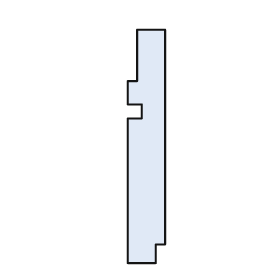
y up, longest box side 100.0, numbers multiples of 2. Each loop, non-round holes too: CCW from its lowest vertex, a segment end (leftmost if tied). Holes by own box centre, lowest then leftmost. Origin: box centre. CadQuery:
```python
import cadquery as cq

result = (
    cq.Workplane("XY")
    .moveTo(-8.0, -50.0)
    .lineTo(4.0, -50.0)
    .lineTo(4.0, -42.0)
    .lineTo(8.0, -42.0)
    .lineTo(8.0, 50.0)
    .lineTo(-4.0, 50.0)
    .lineTo(-4.0, 28.0)
    .lineTo(-8.0, 28.0)
    .lineTo(-8.0, 18.0)
    .lineTo(-2.0, 18.0)
    .lineTo(-2.0, 12.0)
    .lineTo(-8.0, 12.0)
    .close()
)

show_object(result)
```